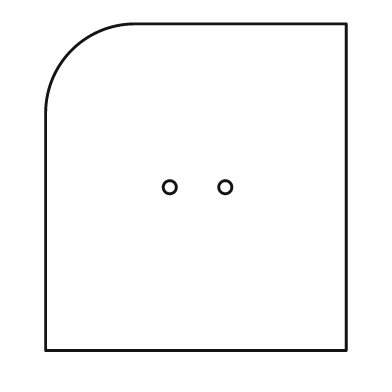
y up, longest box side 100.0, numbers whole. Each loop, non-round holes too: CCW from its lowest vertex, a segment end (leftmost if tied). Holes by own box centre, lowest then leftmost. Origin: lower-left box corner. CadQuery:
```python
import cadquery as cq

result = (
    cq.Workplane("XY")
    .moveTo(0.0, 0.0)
    .lineTo(92.0, 0.0)
    .lineTo(92.0, 100.0)
    .lineTo(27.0, 100.0)
    .threePointArc((8.0, 92.0), (0.0, 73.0))
    .close()
    .moveTo(38.0, 50.0)
    .circle(2.0)
    .moveTo(55.0, 50.0)
    .circle(2.0)
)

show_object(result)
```